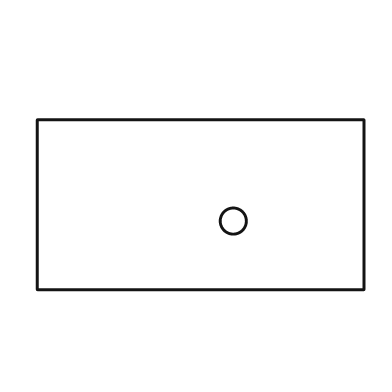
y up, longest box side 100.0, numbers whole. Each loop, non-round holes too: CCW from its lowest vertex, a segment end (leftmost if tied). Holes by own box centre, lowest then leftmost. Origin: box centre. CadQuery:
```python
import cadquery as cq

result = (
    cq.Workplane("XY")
    .moveTo(-50.0, -26.0)
    .lineTo(50.0, -26.0)
    .lineTo(50.0, 26.0)
    .lineTo(-50.0, 26.0)
    .close()
    .moveTo(10.0, -5.0)
    .circle(4.0)
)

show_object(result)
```